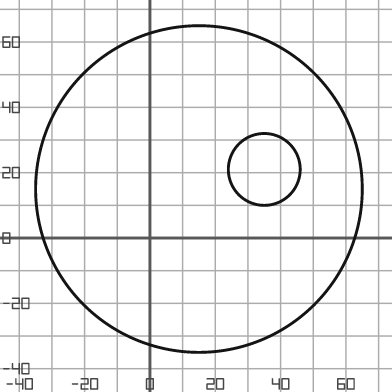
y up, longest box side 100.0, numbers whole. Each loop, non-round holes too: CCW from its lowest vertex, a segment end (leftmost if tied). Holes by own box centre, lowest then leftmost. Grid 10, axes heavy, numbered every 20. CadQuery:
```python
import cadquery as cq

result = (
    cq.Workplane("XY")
    .moveTo(15.0, 15.0)
    .circle(50.0)
    .moveTo(35.0, 21.0)
    .circle(11.0)
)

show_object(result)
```